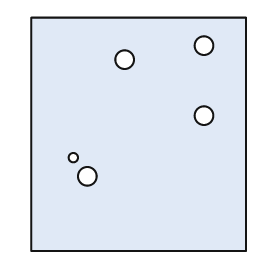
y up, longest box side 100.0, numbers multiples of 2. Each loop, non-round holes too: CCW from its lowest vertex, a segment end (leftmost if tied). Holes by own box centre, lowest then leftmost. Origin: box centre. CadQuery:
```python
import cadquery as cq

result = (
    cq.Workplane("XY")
    .moveTo(-46.0, -50.0)
    .lineTo(46.0, -50.0)
    .lineTo(46.0, 50.0)
    .lineTo(-46.0, 50.0)
    .close()
    .moveTo(-22.0, -18.0)
    .circle(4.0)
    .moveTo(-28.0, -10.0)
    .circle(2.0)
    .moveTo(28.0, 8.0)
    .circle(4.0)
    .moveTo(-6.0, 32.0)
    .circle(4.0)
    .moveTo(28.0, 38.0)
    .circle(4.0)
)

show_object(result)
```